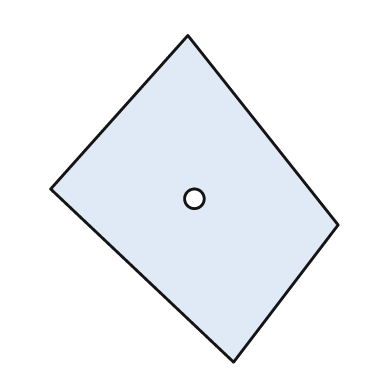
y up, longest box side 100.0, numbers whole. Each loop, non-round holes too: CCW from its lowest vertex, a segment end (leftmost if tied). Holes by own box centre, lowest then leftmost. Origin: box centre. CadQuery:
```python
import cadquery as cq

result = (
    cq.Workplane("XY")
    .moveTo(12.0, -50.0)
    .lineTo(44.0, -8.0)
    .lineTo(-2.0, 50.0)
    .lineTo(-44.0, 3.0)
    .close()
    .moveTo(0.0, 0.0)
    .circle(3.0)
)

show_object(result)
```